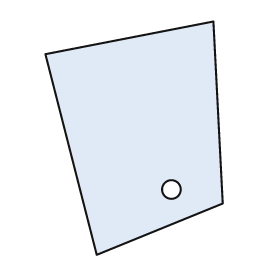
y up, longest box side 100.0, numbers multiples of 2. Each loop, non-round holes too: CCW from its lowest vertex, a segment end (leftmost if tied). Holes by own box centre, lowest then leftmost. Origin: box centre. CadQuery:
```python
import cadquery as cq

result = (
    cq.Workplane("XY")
    .moveTo(-16.0, -50.0)
    .lineTo(38.0, -28.0)
    .lineTo(34.0, 50.0)
    .lineTo(-38.0, 36.0)
    .close()
    .moveTo(16.0, -22.0)
    .circle(4.0)
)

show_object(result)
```